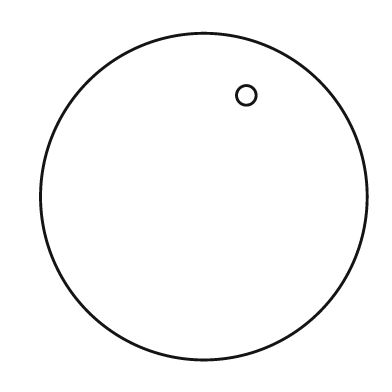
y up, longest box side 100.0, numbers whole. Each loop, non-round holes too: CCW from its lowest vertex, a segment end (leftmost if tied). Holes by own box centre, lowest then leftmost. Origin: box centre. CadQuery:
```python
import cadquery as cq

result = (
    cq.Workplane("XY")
    .moveTo(0.0, 0.0)
    .circle(50.0)
    .moveTo(13.0, 31.0)
    .circle(3.0)
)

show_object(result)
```